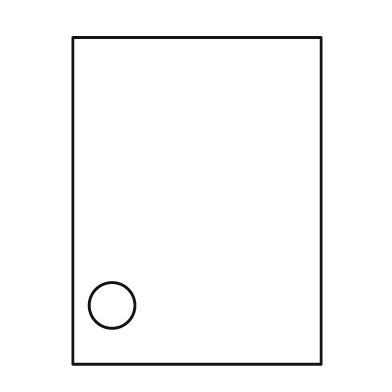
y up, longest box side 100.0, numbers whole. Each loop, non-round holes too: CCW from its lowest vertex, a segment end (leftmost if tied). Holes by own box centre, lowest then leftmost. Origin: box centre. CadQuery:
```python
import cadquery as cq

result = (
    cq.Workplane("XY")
    .moveTo(-38.0, -50.0)
    .lineTo(38.0, -50.0)
    .lineTo(38.0, 50.0)
    .lineTo(-38.0, 50.0)
    .close()
    .moveTo(-26.0, -32.0)
    .circle(7.0)
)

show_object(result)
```